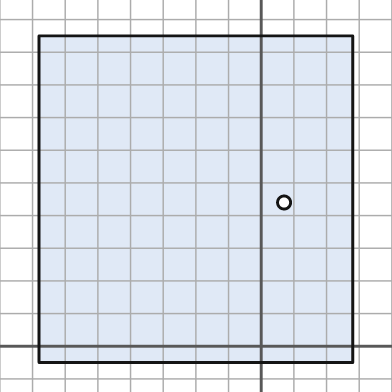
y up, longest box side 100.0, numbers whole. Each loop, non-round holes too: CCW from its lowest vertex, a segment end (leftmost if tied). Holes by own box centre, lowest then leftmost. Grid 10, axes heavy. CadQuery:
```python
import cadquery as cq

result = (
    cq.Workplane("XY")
    .moveTo(-68.0, -5.0)
    .lineTo(28.0, -5.0)
    .lineTo(28.0, 95.0)
    .lineTo(-68.0, 95.0)
    .close()
    .moveTo(7.0, 44.0)
    .circle(2.0)
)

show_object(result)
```